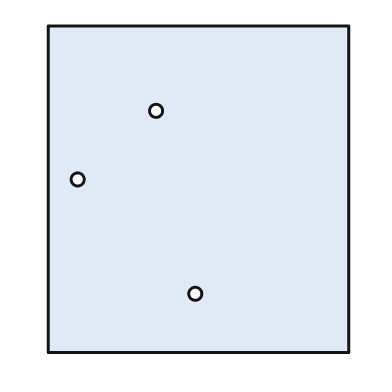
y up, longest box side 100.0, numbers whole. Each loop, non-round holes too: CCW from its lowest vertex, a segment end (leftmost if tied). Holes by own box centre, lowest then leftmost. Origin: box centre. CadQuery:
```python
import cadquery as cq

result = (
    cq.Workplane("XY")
    .moveTo(-46.0, -50.0)
    .lineTo(46.0, -50.0)
    .lineTo(46.0, 50.0)
    .lineTo(-46.0, 50.0)
    .close()
    .moveTo(-1.0, -32.0)
    .circle(2.0)
    .moveTo(-37.0, 3.0)
    .circle(2.0)
    .moveTo(-13.0, 24.0)
    .circle(2.0)
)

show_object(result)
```